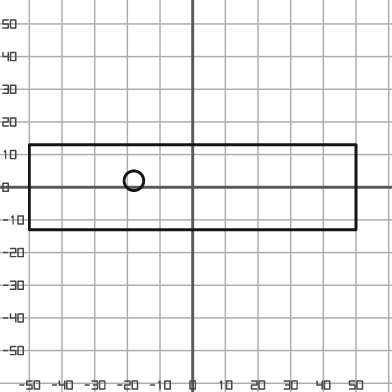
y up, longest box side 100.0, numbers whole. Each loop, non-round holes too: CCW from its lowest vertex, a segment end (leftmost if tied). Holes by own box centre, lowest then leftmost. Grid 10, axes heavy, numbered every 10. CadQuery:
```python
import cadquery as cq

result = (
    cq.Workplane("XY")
    .moveTo(-50.0, -13.0)
    .lineTo(50.0, -13.0)
    .lineTo(50.0, 13.0)
    .lineTo(-50.0, 13.0)
    .close()
    .moveTo(-18.0, 2.0)
    .circle(3.0)
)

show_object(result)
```